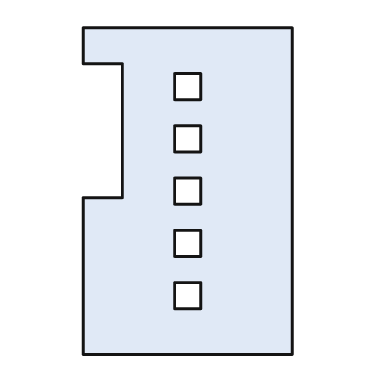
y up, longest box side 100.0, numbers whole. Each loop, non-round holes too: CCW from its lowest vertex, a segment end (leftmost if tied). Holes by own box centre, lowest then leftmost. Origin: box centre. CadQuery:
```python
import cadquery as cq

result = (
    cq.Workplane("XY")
    .moveTo(-32.0, -50.0)
    .lineTo(32.0, -50.0)
    .lineTo(32.0, 50.0)
    .lineTo(-32.0, 50.0)
    .lineTo(-32.0, 39.0)
    .lineTo(-20.0, 39.0)
    .lineTo(-20.0, -2.0)
    .lineTo(-32.0, -2.0)
    .close()
    .moveTo(-4.0, -36.0)
    .lineTo(4.0, -36.0)
    .lineTo(4.0, -28.0)
    .lineTo(-4.0, -28.0)
    .close()
    .moveTo(-4.0, -20.0)
    .lineTo(4.0, -20.0)
    .lineTo(4.0, -12.0)
    .lineTo(-4.0, -12.0)
    .close()
    .moveTo(-4.0, -4.0)
    .lineTo(4.0, -4.0)
    .lineTo(4.0, 4.0)
    .lineTo(-4.0, 4.0)
    .close()
    .moveTo(-4.0, 12.0)
    .lineTo(4.0, 12.0)
    .lineTo(4.0, 20.0)
    .lineTo(-4.0, 20.0)
    .close()
    .moveTo(-4.0, 28.0)
    .lineTo(4.0, 28.0)
    .lineTo(4.0, 36.0)
    .lineTo(-4.0, 36.0)
    .close()
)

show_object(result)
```